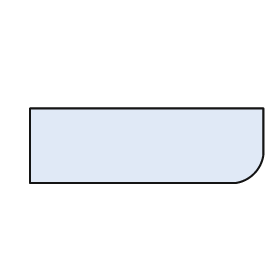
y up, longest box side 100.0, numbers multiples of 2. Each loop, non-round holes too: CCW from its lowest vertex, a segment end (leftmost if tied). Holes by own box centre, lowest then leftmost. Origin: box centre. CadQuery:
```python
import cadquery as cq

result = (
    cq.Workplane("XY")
    .moveTo(-50.0, -16.0)
    .lineTo(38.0, -16.0)
    .threePointArc((46.0, -12.0), (50.0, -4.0))
    .lineTo(50.0, 16.0)
    .lineTo(-50.0, 16.0)
    .close()
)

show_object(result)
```